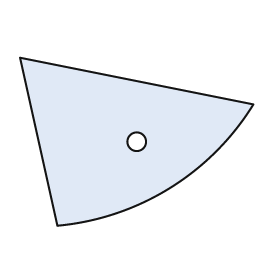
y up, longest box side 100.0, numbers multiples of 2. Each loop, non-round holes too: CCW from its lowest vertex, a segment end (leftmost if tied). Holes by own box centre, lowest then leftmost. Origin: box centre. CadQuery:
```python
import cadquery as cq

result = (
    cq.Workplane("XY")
    .moveTo(-34.0, -36.0)
    .threePointArc((14.0, -20.0), (50.0, 16.0))
    .lineTo(-50.0, 36.0)
    .close()
    .moveTo(0.0, 0.0)
    .circle(4.0)
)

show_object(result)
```